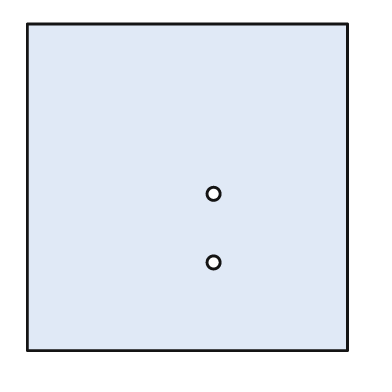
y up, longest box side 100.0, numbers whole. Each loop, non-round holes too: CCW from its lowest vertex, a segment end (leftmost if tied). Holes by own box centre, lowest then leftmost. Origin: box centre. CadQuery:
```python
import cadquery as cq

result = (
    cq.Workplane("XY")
    .moveTo(-49.0, -50.0)
    .lineTo(49.0, -50.0)
    .lineTo(49.0, 50.0)
    .lineTo(-49.0, 50.0)
    .close()
    .moveTo(8.0, -23.0)
    .circle(2.0)
    .moveTo(8.0, -2.0)
    .circle(2.0)
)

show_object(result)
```